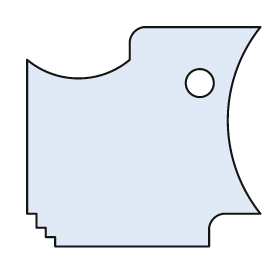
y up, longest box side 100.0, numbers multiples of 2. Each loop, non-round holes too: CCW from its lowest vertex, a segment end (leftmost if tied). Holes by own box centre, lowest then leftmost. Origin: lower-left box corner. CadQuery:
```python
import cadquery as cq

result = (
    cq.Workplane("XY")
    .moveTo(12.0, 0.0)
    .lineTo(78.0, 0.0)
    .lineTo(78.0, 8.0)
    .threePointArc((80.0, 12.0), (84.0, 14.0))
    .lineTo(100.0, 14.0)
    .threePointArc((86.0, 54.0), (100.0, 94.0))
    .lineTo(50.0, 94.0)
    .threePointArc((46.0, 92.0), (44.0, 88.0))
    .lineTo(44.0, 80.0)
    .threePointArc((22.0, 72.0), (0.0, 80.0))
    .lineTo(0.0, 14.0)
    .lineTo(4.0, 14.0)
    .lineTo(4.0, 8.0)
    .lineTo(8.0, 8.0)
    .lineTo(8.0, 4.0)
    .lineTo(12.0, 4.0)
    .close()
    .moveTo(74.0, 70.0)
    .circle(6.0)
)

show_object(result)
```